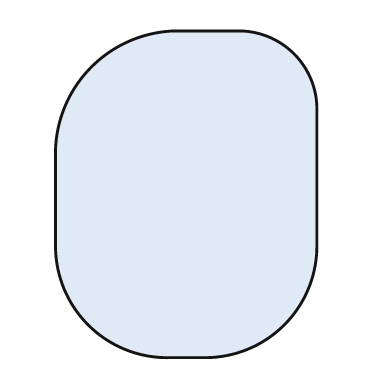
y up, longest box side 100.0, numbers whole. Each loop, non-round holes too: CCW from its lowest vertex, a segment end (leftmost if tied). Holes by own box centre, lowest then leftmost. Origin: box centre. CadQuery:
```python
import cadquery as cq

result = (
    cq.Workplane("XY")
    .moveTo(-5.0, -50.0)
    .lineTo(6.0, -50.0)
    .threePointArc((30.0, -40.0), (40.0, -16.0))
    .lineTo(40.0, 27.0)
    .threePointArc((33.0, 43.0), (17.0, 50.0))
    .lineTo(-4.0, 50.0)
    .threePointArc((-29.0, 39.0), (-40.0, 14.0))
    .lineTo(-40.0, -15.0)
    .threePointArc((-30.0, -40.0), (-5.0, -50.0))
    .close()
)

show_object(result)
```